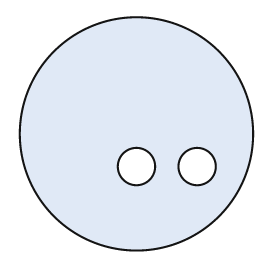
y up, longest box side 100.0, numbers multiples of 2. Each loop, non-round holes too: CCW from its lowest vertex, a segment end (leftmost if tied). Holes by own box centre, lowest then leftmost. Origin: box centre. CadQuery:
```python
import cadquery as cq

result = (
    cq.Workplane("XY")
    .moveTo(0.0, 0.0)
    .circle(50.0)
    .moveTo(0.0, -14.0)
    .circle(8.0)
    .moveTo(26.0, -14.0)
    .circle(8.0)
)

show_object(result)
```